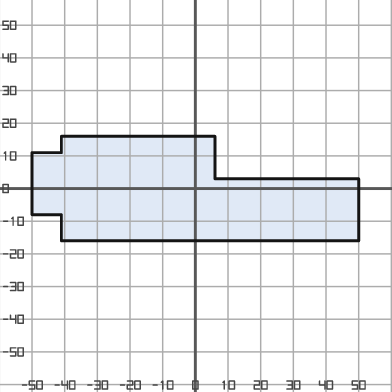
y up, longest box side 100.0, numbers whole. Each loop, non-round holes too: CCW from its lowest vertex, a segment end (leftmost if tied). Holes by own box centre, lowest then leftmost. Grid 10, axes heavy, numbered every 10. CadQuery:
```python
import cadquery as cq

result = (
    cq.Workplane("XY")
    .moveTo(-41.0, -16.0)
    .lineTo(50.0, -16.0)
    .lineTo(50.0, 3.0)
    .lineTo(6.0, 3.0)
    .lineTo(6.0, 16.0)
    .lineTo(-41.0, 16.0)
    .lineTo(-41.0, 11.0)
    .lineTo(-50.0, 11.0)
    .lineTo(-50.0, -8.0)
    .lineTo(-41.0, -8.0)
    .close()
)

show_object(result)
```